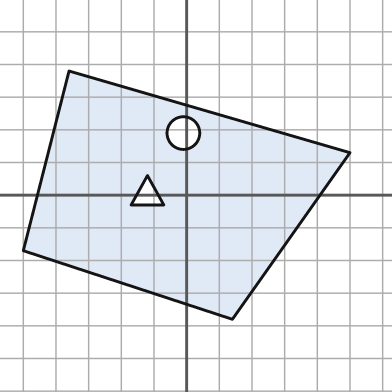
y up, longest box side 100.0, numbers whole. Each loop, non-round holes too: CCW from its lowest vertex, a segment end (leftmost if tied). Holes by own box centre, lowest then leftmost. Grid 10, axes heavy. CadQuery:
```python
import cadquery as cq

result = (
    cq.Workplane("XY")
    .moveTo(14.0, -38.0)
    .lineTo(50.0, 13.0)
    .lineTo(-36.0, 38.0)
    .lineTo(-50.0, -17.0)
    .close()
    .moveTo(-17.0, -3.0)
    .lineTo(-7.0, -3.0)
    .lineTo(-12.0, 6.0)
    .close()
    .moveTo(-1.0, 19.0)
    .circle(5.0)
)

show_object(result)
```